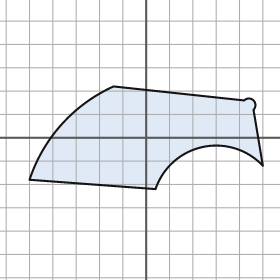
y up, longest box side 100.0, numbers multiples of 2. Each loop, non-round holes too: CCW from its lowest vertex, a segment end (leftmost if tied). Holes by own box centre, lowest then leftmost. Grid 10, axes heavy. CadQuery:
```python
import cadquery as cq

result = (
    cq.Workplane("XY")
    .moveTo(4.0, -22.0)
    .threePointArc((24.0, -4.0), (50.0, -12.0))
    .lineTo(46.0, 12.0)
    .threePointArc((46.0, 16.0), (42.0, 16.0))
    .lineTo(-14.0, 22.0)
    .threePointArc((-36.0, 6.0), (-50.0, -18.0))
    .close()
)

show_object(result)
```